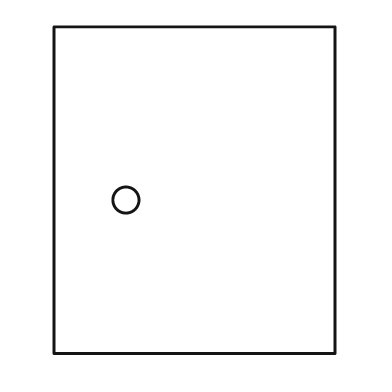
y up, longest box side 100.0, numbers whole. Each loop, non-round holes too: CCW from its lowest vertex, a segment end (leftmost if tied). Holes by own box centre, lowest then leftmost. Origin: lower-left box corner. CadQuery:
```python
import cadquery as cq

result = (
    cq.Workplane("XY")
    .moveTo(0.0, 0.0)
    .lineTo(86.0, 0.0)
    .lineTo(86.0, 100.0)
    .lineTo(0.0, 100.0)
    .close()
    .moveTo(22.0, 47.0)
    .circle(4.0)
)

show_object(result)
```